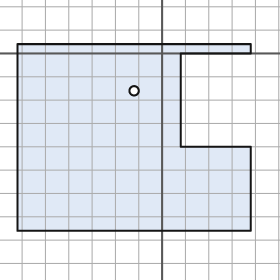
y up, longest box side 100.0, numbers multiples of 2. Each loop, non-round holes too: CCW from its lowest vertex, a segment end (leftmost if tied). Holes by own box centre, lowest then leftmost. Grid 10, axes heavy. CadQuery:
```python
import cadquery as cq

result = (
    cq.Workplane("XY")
    .moveTo(-62.0, -76.0)
    .lineTo(38.0, -76.0)
    .lineTo(38.0, -40.0)
    .lineTo(8.0, -40.0)
    .lineTo(8.0, 0.0)
    .lineTo(38.0, 0.0)
    .lineTo(38.0, 4.0)
    .lineTo(-62.0, 4.0)
    .close()
    .moveTo(-12.0, -16.0)
    .circle(2.0)
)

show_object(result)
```